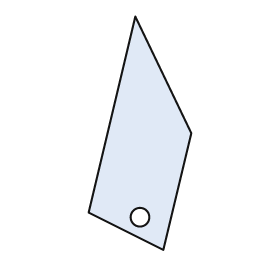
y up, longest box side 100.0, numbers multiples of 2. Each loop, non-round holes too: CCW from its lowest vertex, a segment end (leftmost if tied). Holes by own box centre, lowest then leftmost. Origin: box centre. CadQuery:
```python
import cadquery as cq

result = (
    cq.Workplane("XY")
    .moveTo(10.0, -50.0)
    .lineTo(22.0, 0.0)
    .lineTo(-2.0, 50.0)
    .lineTo(-22.0, -34.0)
    .close()
    .moveTo(0.0, -36.0)
    .circle(4.0)
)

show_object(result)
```